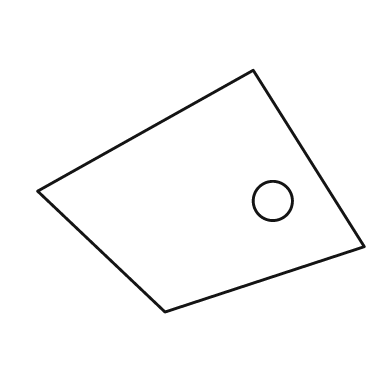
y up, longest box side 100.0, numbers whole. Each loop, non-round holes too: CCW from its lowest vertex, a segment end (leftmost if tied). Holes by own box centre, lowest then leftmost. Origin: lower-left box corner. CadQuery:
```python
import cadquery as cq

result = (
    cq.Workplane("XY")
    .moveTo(39.0, 0.0)
    .lineTo(100.0, 20.0)
    .lineTo(66.0, 74.0)
    .lineTo(0.0, 37.0)
    .close()
    .moveTo(72.0, 34.0)
    .circle(6.0)
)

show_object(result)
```